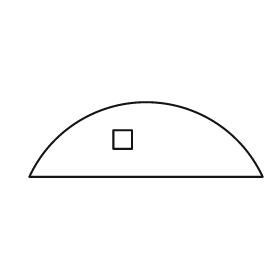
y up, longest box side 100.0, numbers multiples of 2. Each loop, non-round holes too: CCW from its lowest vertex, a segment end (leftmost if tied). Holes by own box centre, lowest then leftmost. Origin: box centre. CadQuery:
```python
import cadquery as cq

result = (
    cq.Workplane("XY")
    .moveTo(-50.0, -16.0)
    .lineTo(50.0, -16.0)
    .threePointArc((0.0, 16.0), (-50.0, -16.0))
    .close()
    .moveTo(-14.0, -4.0)
    .lineTo(-6.0, -4.0)
    .lineTo(-6.0, 4.0)
    .lineTo(-14.0, 4.0)
    .close()
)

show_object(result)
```